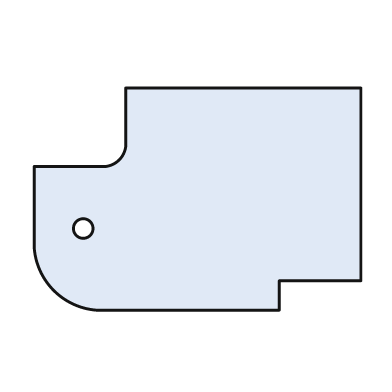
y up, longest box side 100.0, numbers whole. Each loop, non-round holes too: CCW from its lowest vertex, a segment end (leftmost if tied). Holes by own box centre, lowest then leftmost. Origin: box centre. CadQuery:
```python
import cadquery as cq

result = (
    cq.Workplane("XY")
    .moveTo(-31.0, -34.0)
    .lineTo(25.0, -34.0)
    .lineTo(25.0, -25.0)
    .lineTo(50.0, -25.0)
    .lineTo(50.0, 34.0)
    .lineTo(-22.0, 34.0)
    .lineTo(-22.0, 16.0)
    .threePointArc((-24.0, 12.0), (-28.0, 10.0))
    .lineTo(-50.0, 10.0)
    .lineTo(-50.0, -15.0)
    .threePointArc((-44.0, -28.0), (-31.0, -34.0))
    .close()
    .moveTo(-35.0, -9.0)
    .circle(3.0)
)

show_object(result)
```